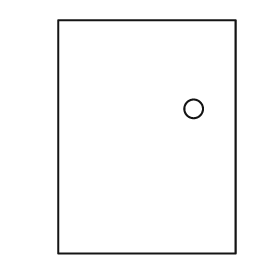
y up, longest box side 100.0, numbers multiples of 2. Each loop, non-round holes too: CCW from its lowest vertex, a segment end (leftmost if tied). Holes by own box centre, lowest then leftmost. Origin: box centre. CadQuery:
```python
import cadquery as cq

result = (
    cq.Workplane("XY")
    .moveTo(-38.0, -50.0)
    .lineTo(38.0, -50.0)
    .lineTo(38.0, 50.0)
    .lineTo(-38.0, 50.0)
    .close()
    .moveTo(20.0, 12.0)
    .circle(4.0)
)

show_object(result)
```